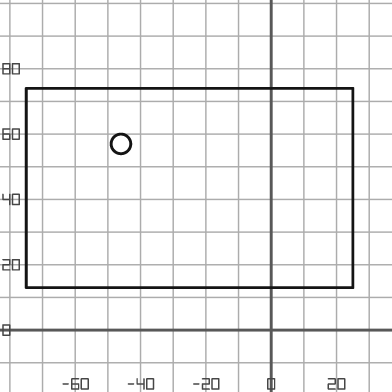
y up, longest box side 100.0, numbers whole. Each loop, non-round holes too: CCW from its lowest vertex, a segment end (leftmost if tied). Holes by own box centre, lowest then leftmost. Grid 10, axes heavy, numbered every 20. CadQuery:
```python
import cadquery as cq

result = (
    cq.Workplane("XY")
    .moveTo(-75.0, 13.0)
    .lineTo(25.0, 13.0)
    .lineTo(25.0, 74.0)
    .lineTo(-75.0, 74.0)
    .close()
    .moveTo(-46.0, 57.0)
    .circle(3.0)
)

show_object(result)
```